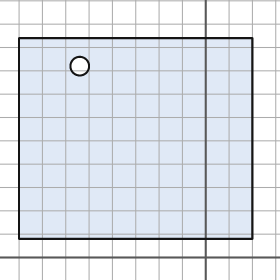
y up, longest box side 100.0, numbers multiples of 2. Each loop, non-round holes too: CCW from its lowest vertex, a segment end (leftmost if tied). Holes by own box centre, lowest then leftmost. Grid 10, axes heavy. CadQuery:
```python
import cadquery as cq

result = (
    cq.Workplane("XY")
    .moveTo(-80.0, 8.0)
    .lineTo(20.0, 8.0)
    .lineTo(20.0, 94.0)
    .lineTo(-80.0, 94.0)
    .close()
    .moveTo(-54.0, 82.0)
    .circle(4.0)
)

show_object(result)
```